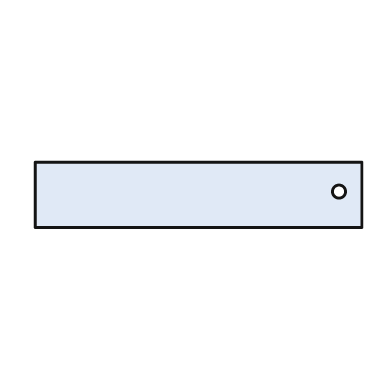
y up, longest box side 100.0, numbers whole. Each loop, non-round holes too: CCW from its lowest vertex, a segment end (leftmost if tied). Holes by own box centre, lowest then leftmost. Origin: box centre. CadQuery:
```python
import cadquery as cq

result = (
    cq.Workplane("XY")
    .moveTo(-50.0, -10.0)
    .lineTo(50.0, -10.0)
    .lineTo(50.0, 10.0)
    .lineTo(-50.0, 10.0)
    .close()
    .moveTo(43.0, 1.0)
    .circle(2.0)
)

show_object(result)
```